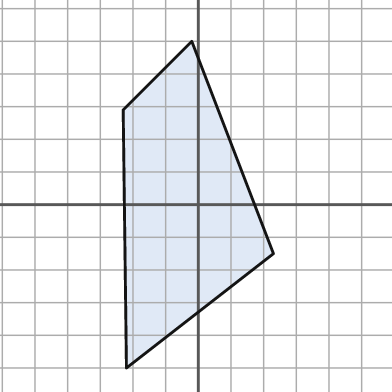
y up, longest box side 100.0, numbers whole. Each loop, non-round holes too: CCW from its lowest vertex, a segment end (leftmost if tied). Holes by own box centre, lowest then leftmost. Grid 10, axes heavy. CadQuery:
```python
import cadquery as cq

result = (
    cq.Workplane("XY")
    .moveTo(-22.0, -50.0)
    .lineTo(23.0, -15.0)
    .lineTo(-2.0, 50.0)
    .lineTo(-23.0, 29.0)
    .close()
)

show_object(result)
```